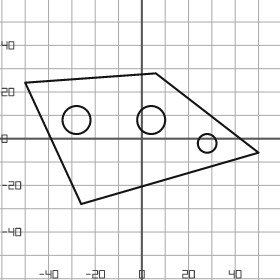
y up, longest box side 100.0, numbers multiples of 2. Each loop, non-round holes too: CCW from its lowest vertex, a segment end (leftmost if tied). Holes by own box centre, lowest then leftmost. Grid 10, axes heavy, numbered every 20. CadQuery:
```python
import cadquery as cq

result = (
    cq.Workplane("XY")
    .moveTo(-26.0, -28.0)
    .lineTo(50.0, -6.0)
    .lineTo(6.0, 28.0)
    .lineTo(-50.0, 24.0)
    .close()
    .moveTo(28.0, -2.0)
    .circle(4.0)
    .moveTo(-28.0, 8.0)
    .circle(6.0)
    .moveTo(4.0, 8.0)
    .circle(6.0)
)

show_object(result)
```